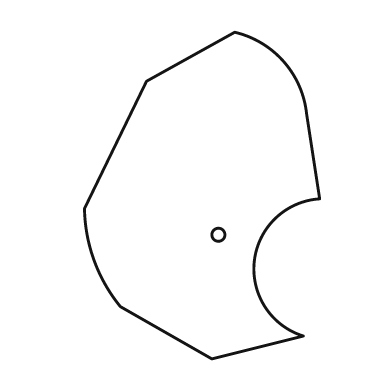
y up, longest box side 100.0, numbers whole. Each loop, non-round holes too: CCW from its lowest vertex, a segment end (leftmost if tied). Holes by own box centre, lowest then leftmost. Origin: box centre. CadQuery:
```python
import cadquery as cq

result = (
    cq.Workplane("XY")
    .moveTo(3.0, -50.0)
    .lineTo(31.0, -43.0)
    .threePointArc((16.0, -20.0), (36.0, -1.0))
    .lineTo(32.0, 25.0)
    .threePointArc((25.0, 41.0), (10.0, 50.0))
    .lineTo(-17.0, 35.0)
    .lineTo(-36.0, -4.0)
    .threePointArc((-33.0, -20.0), (-25.0, -34.0))
    .close()
    .moveTo(5.0, -12.0)
    .circle(2.0)
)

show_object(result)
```